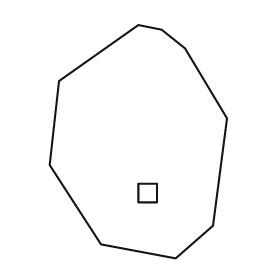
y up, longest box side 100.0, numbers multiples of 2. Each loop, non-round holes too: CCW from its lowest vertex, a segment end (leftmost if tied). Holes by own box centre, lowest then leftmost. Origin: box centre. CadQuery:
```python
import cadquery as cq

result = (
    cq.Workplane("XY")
    .moveTo(16.0, -50.0)
    .lineTo(32.0, -36.0)
    .lineTo(38.0, 10.0)
    .lineTo(20.0, 40.0)
    .lineTo(10.0, 48.0)
    .lineTo(0.0, 50.0)
    .lineTo(-34.0, 26.0)
    .lineTo(-38.0, -10.0)
    .lineTo(-16.0, -44.0)
    .close()
    .moveTo(0.0, -26.0)
    .lineTo(8.0, -26.0)
    .lineTo(8.0, -18.0)
    .lineTo(0.0, -18.0)
    .close()
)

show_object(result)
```